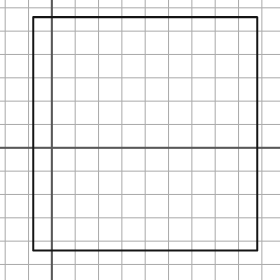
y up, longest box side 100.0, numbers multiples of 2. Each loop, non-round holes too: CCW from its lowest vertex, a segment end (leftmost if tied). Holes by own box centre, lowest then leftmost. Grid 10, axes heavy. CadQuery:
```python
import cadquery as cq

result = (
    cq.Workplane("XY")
    .moveTo(-8.0, -44.0)
    .lineTo(88.0, -44.0)
    .lineTo(88.0, 56.0)
    .lineTo(-8.0, 56.0)
    .close()
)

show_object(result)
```